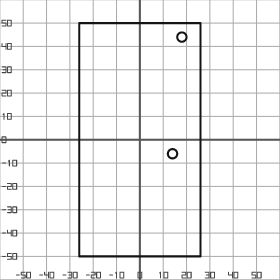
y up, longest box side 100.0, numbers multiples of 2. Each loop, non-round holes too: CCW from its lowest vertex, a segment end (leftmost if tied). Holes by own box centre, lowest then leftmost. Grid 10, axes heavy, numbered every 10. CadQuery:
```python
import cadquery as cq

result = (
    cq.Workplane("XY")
    .moveTo(-26.0, -50.0)
    .lineTo(26.0, -50.0)
    .lineTo(26.0, 50.0)
    .lineTo(-26.0, 50.0)
    .close()
    .moveTo(14.0, -6.0)
    .circle(2.0)
    .moveTo(18.0, 44.0)
    .circle(2.0)
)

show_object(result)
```